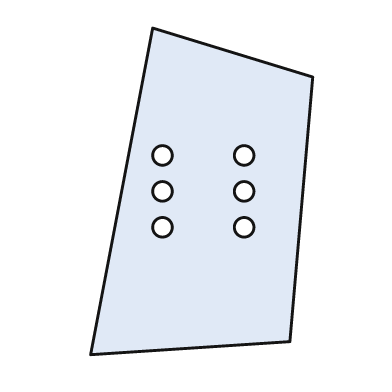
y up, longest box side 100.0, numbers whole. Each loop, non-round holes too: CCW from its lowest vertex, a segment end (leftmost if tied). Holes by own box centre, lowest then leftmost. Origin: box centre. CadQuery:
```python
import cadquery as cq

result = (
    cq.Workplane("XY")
    .moveTo(-34.0, -50.0)
    .lineTo(27.0, -46.0)
    .lineTo(34.0, 35.0)
    .lineTo(-15.0, 50.0)
    .close()
    .moveTo(-12.0, -11.0)
    .circle(3.0)
    .moveTo(13.0, -11.0)
    .circle(3.0)
    .moveTo(-12.0, 0.0)
    .circle(3.0)
    .moveTo(13.0, 0.0)
    .circle(3.0)
    .moveTo(-12.0, 11.0)
    .circle(3.0)
    .moveTo(13.0, 11.0)
    .circle(3.0)
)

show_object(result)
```